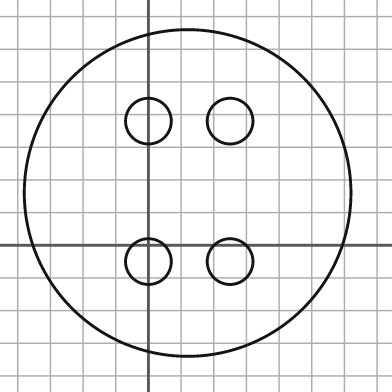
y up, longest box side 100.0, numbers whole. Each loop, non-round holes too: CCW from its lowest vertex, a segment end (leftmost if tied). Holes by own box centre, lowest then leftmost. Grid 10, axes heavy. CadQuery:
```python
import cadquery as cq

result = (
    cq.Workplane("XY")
    .moveTo(12.0, 16.0)
    .circle(50.0)
    .moveTo(0.0, -5.0)
    .circle(7.0)
    .moveTo(25.0, -5.0)
    .circle(7.0)
    .moveTo(0.0, 38.0)
    .circle(7.0)
    .moveTo(25.0, 38.0)
    .circle(7.0)
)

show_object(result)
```